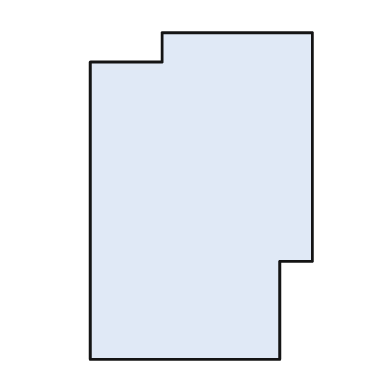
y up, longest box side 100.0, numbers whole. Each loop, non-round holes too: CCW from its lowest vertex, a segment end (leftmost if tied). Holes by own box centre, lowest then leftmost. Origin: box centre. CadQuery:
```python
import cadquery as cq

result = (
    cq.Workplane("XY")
    .moveTo(-34.0, -50.0)
    .lineTo(24.0, -50.0)
    .lineTo(24.0, -20.0)
    .lineTo(34.0, -20.0)
    .lineTo(34.0, 50.0)
    .lineTo(-12.0, 50.0)
    .lineTo(-12.0, 41.0)
    .lineTo(-34.0, 41.0)
    .close()
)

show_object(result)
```